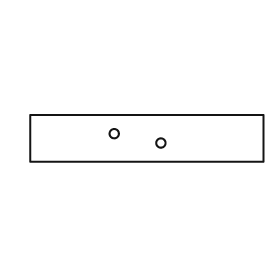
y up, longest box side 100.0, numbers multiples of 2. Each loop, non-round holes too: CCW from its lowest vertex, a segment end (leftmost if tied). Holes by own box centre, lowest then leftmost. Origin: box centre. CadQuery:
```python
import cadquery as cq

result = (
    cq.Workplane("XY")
    .moveTo(-50.0, -10.0)
    .lineTo(50.0, -10.0)
    .lineTo(50.0, 10.0)
    .lineTo(-50.0, 10.0)
    .close()
    .moveTo(6.0, -2.0)
    .circle(2.0)
    .moveTo(-14.0, 2.0)
    .circle(2.0)
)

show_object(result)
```